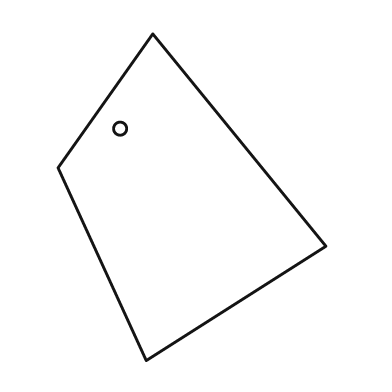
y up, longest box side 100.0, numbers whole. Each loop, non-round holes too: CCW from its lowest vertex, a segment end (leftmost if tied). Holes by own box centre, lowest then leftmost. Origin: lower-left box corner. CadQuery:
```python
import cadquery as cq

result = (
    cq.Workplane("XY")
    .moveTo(27.0, 0.0)
    .lineTo(82.0, 35.0)
    .lineTo(29.0, 100.0)
    .lineTo(0.0, 59.0)
    .close()
    .moveTo(19.0, 71.0)
    .circle(2.0)
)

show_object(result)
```